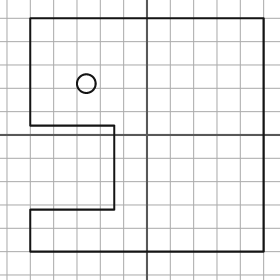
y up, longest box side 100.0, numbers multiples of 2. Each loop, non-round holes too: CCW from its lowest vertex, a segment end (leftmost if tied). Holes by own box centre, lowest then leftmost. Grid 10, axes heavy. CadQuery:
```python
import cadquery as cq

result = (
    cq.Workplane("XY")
    .moveTo(-50.0, -50.0)
    .lineTo(50.0, -50.0)
    .lineTo(50.0, 50.0)
    .lineTo(-50.0, 50.0)
    .lineTo(-50.0, 4.0)
    .lineTo(-14.0, 4.0)
    .lineTo(-14.0, -32.0)
    .lineTo(-50.0, -32.0)
    .close()
    .moveTo(-26.0, 22.0)
    .circle(4.0)
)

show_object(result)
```